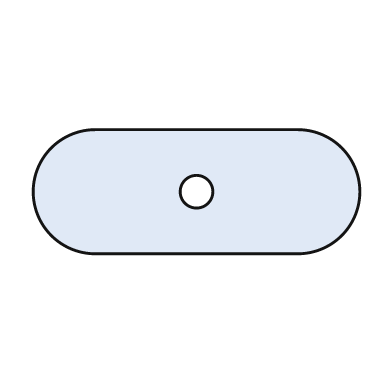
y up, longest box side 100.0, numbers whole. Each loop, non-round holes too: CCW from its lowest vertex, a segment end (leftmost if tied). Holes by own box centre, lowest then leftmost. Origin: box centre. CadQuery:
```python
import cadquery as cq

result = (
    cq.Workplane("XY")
    .moveTo(-31.0, -19.0)
    .lineTo(31.0, -19.0)
    .threePointArc((50.0, 0.0), (31.0, 19.0))
    .lineTo(-31.0, 19.0)
    .threePointArc((-50.0, 0.0), (-31.0, -19.0))
    .close()
    .moveTo(0.0, 0.0)
    .circle(5.0)
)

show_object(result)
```